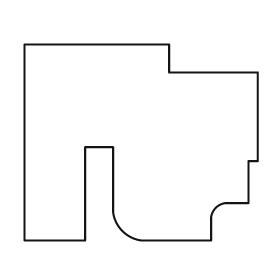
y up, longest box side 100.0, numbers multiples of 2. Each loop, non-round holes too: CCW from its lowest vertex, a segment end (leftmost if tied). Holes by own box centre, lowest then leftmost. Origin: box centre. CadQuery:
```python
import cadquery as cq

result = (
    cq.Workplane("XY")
    .moveTo(-50.0, -42.0)
    .lineTo(-24.0, -42.0)
    .lineTo(-24.0, -2.0)
    .lineTo(-12.0, -2.0)
    .lineTo(-12.0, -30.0)
    .threePointArc((-8.0, -38.0), (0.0, -42.0))
    .lineTo(30.0, -42.0)
    .lineTo(30.0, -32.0)
    .threePointArc((32.0, -28.0), (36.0, -26.0))
    .lineTo(46.0, -26.0)
    .lineTo(46.0, -8.0)
    .lineTo(50.0, -8.0)
    .lineTo(50.0, 30.0)
    .lineTo(12.0, 30.0)
    .lineTo(12.0, 42.0)
    .lineTo(-50.0, 42.0)
    .close()
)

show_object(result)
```